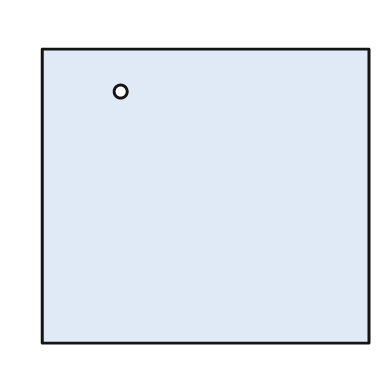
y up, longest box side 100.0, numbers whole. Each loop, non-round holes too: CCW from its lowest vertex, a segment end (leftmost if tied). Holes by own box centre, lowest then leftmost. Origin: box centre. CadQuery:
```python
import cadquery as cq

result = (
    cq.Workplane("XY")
    .moveTo(-50.0, -45.0)
    .lineTo(50.0, -45.0)
    .lineTo(50.0, 45.0)
    .lineTo(-50.0, 45.0)
    .close()
    .moveTo(-26.0, 32.0)
    .circle(2.0)
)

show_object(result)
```